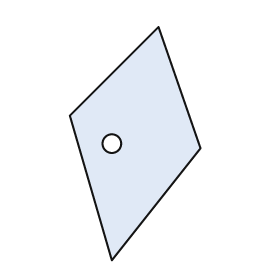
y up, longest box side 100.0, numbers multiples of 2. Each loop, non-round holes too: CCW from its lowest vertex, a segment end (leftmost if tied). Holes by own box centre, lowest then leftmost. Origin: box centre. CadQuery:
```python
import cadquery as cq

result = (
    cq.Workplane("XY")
    .moveTo(-10.0, -50.0)
    .lineTo(28.0, -2.0)
    .lineTo(10.0, 50.0)
    .lineTo(-28.0, 12.0)
    .close()
    .moveTo(-10.0, 0.0)
    .circle(4.0)
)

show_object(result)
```